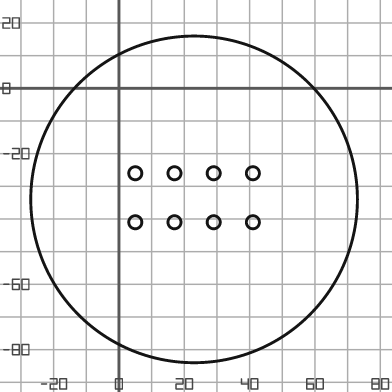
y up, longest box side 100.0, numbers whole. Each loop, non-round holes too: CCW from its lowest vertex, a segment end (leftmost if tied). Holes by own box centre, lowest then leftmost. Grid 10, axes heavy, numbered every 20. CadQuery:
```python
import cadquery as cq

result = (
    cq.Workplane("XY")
    .moveTo(23.0, -34.0)
    .circle(50.0)
    .moveTo(5.0, -41.0)
    .circle(2.0)
    .moveTo(17.0, -41.0)
    .circle(2.0)
    .moveTo(29.0, -41.0)
    .circle(2.0)
    .moveTo(41.0, -41.0)
    .circle(2.0)
    .moveTo(5.0, -26.0)
    .circle(2.0)
    .moveTo(17.0, -26.0)
    .circle(2.0)
    .moveTo(29.0, -26.0)
    .circle(2.0)
    .moveTo(41.0, -26.0)
    .circle(2.0)
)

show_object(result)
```